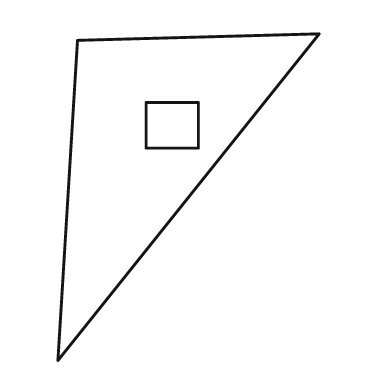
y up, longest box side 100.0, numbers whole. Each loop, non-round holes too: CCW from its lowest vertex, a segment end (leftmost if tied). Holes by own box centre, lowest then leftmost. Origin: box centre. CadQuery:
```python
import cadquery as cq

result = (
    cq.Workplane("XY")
    .moveTo(-40.0, -50.0)
    .lineTo(40.0, 50.0)
    .lineTo(-34.0, 48.0)
    .close()
    .moveTo(-13.0, 15.0)
    .lineTo(3.0, 15.0)
    .lineTo(3.0, 29.0)
    .lineTo(-13.0, 29.0)
    .close()
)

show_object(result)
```